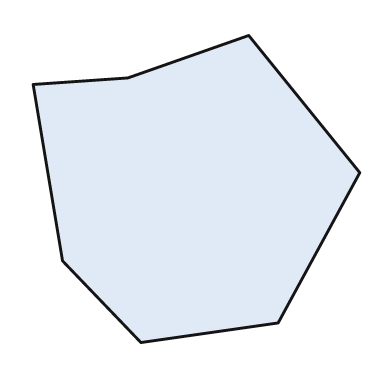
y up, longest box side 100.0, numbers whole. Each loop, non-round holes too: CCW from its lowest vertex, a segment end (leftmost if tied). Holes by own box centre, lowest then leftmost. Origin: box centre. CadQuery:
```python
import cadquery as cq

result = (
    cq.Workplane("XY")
    .moveTo(-17.0, -47.0)
    .lineTo(25.0, -41.0)
    .lineTo(50.0, 5.0)
    .lineTo(16.0, 47.0)
    .lineTo(-21.0, 34.0)
    .lineTo(-50.0, 32.0)
    .lineTo(-41.0, -22.0)
    .close()
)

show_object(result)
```